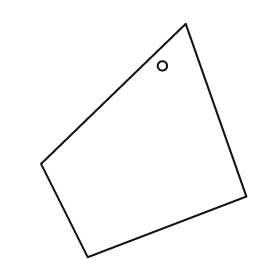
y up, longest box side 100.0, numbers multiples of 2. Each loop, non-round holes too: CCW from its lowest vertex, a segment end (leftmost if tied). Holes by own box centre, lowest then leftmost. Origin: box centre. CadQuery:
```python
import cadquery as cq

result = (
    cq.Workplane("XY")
    .moveTo(-24.0, -50.0)
    .lineTo(44.0, -24.0)
    .lineTo(18.0, 50.0)
    .lineTo(-44.0, -10.0)
    .close()
    .moveTo(8.0, 32.0)
    .circle(2.0)
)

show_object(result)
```